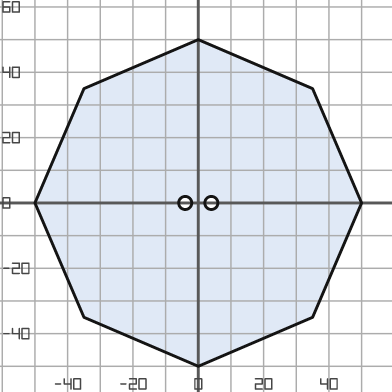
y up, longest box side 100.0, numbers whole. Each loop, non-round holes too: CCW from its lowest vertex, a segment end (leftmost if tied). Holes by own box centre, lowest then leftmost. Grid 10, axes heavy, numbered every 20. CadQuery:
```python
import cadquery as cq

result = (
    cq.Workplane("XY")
    .moveTo(0.0, -50.0)
    .lineTo(35.0, -35.0)
    .lineTo(50.0, 0.0)
    .lineTo(35.0, 35.0)
    .lineTo(0.0, 50.0)
    .lineTo(-35.0, 35.0)
    .lineTo(-50.0, 0.0)
    .lineTo(-35.0, -35.0)
    .close()
    .moveTo(-4.0, 0.0)
    .circle(2.0)
    .moveTo(4.0, 0.0)
    .circle(2.0)
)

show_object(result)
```